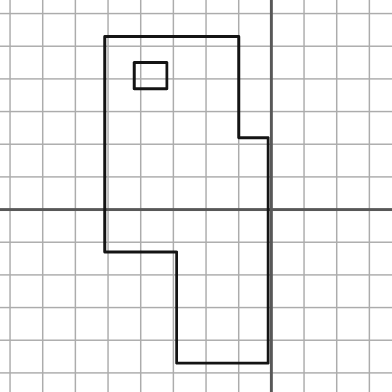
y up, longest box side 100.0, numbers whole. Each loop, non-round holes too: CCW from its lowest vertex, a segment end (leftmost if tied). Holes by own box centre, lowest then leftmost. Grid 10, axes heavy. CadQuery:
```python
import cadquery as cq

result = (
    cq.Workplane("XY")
    .moveTo(-29.0, -47.0)
    .lineTo(-1.0, -47.0)
    .lineTo(-1.0, 22.0)
    .lineTo(-10.0, 22.0)
    .lineTo(-10.0, 53.0)
    .lineTo(-51.0, 53.0)
    .lineTo(-51.0, -13.0)
    .lineTo(-29.0, -13.0)
    .close()
    .moveTo(-42.0, 37.0)
    .lineTo(-32.0, 37.0)
    .lineTo(-32.0, 45.0)
    .lineTo(-42.0, 45.0)
    .close()
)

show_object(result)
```